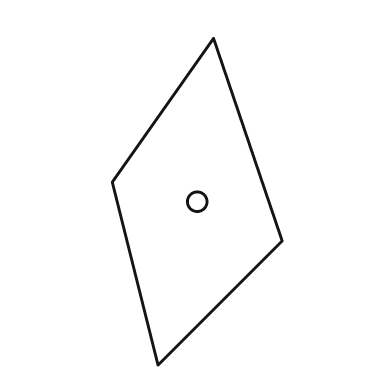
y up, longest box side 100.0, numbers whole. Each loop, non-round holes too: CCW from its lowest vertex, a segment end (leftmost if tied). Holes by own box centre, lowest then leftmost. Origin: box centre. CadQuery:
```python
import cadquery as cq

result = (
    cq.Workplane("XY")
    .moveTo(-12.0, -50.0)
    .lineTo(26.0, -12.0)
    .lineTo(5.0, 50.0)
    .lineTo(-26.0, 6.0)
    .close()
    .moveTo(0.0, 0.0)
    .circle(3.0)
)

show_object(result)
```